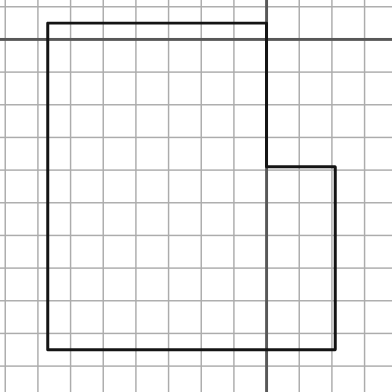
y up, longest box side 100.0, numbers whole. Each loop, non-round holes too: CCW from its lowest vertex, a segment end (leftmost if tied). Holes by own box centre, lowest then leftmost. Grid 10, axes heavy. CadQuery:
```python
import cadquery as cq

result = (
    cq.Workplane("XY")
    .moveTo(-67.0, -95.0)
    .lineTo(21.0, -95.0)
    .lineTo(21.0, -39.0)
    .lineTo(0.0, -39.0)
    .lineTo(0.0, 5.0)
    .lineTo(-67.0, 5.0)
    .close()
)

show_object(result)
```